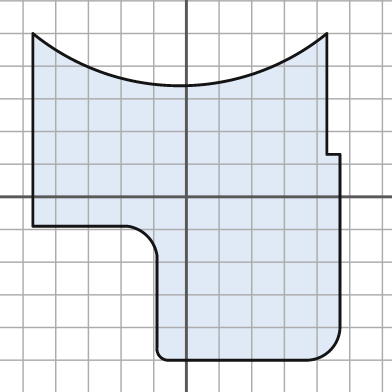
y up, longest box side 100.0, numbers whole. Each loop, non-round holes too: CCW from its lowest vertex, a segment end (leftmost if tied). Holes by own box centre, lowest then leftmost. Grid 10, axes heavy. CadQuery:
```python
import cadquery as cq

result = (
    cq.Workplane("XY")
    .moveTo(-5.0, -50.0)
    .lineTo(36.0, -50.0)
    .threePointArc((44.0, -47.0), (47.0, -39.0))
    .lineTo(47.0, 13.0)
    .lineTo(43.0, 13.0)
    .lineTo(43.0, 50.0)
    .threePointArc((-2.0, 34.0), (-47.0, 50.0))
    .lineTo(-47.0, -9.0)
    .lineTo(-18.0, -9.0)
    .threePointArc((-12.0, -12.0), (-9.0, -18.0))
    .lineTo(-9.0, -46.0)
    .threePointArc((-8.0, -49.0), (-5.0, -50.0))
    .close()
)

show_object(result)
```